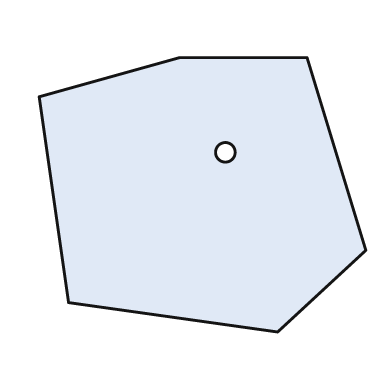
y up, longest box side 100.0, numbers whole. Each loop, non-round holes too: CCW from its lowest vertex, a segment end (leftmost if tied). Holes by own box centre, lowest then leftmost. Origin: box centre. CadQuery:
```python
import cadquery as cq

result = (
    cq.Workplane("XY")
    .moveTo(23.0, -42.0)
    .lineTo(50.0, -17.0)
    .lineTo(32.0, 42.0)
    .lineTo(-7.0, 42.0)
    .lineTo(-50.0, 30.0)
    .lineTo(-41.0, -33.0)
    .close()
    .moveTo(7.0, 13.0)
    .circle(3.0)
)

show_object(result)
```